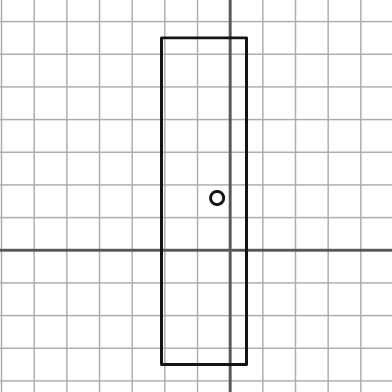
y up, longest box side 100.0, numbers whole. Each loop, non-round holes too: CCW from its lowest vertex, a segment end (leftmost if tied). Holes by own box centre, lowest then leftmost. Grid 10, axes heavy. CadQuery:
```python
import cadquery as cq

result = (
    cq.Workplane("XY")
    .moveTo(-21.0, -35.0)
    .lineTo(5.0, -35.0)
    .lineTo(5.0, 65.0)
    .lineTo(-21.0, 65.0)
    .close()
    .moveTo(-4.0, 16.0)
    .circle(2.0)
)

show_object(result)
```